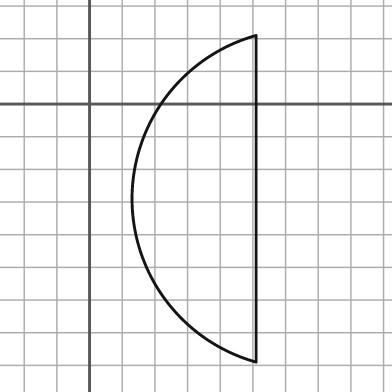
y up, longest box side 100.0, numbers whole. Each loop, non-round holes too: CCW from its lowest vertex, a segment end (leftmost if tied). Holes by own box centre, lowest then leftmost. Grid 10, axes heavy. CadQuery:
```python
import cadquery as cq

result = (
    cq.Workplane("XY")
    .moveTo(51.0, -79.0)
    .lineTo(51.0, 21.0)
    .threePointArc((13.0, -29.0), (51.0, -79.0))
    .close()
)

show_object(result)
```